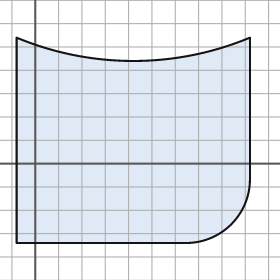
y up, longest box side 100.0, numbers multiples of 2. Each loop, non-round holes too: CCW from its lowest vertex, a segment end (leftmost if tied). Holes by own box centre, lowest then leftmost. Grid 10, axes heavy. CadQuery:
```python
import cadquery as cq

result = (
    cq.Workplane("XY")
    .moveTo(-8.0, -34.0)
    .lineTo(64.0, -34.0)
    .threePointArc((84.0, -26.0), (92.0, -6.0))
    .lineTo(92.0, 54.0)
    .threePointArc((42.0, 44.0), (-8.0, 54.0))
    .close()
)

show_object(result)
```